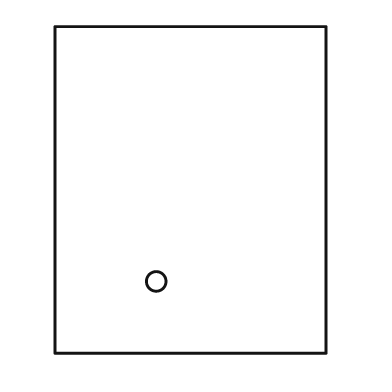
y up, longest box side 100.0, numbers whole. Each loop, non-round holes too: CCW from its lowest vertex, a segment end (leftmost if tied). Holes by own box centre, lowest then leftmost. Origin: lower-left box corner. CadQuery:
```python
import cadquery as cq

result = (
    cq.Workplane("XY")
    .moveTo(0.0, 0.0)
    .lineTo(83.0, 0.0)
    .lineTo(83.0, 100.0)
    .lineTo(0.0, 100.0)
    .close()
    .moveTo(31.0, 22.0)
    .circle(3.0)
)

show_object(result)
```